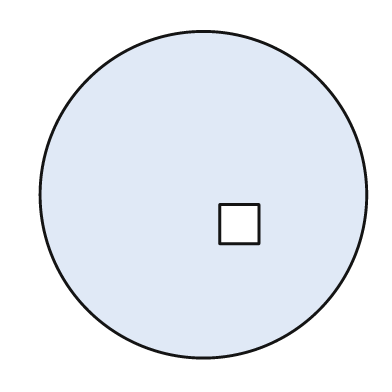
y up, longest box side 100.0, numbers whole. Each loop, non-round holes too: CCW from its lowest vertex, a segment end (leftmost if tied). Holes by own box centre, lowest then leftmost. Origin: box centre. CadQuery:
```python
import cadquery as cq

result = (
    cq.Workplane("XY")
    .moveTo(0.0, 0.0)
    .circle(50.0)
    .moveTo(5.0, -15.0)
    .lineTo(17.0, -15.0)
    .lineTo(17.0, -3.0)
    .lineTo(5.0, -3.0)
    .close()
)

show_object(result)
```